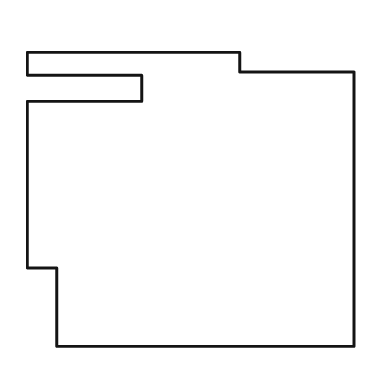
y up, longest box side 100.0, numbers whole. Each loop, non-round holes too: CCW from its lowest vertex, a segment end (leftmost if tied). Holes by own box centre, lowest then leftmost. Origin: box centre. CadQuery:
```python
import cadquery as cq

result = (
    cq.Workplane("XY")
    .moveTo(-41.0, -45.0)
    .lineTo(50.0, -45.0)
    .lineTo(50.0, 39.0)
    .lineTo(15.0, 39.0)
    .lineTo(15.0, 45.0)
    .lineTo(-50.0, 45.0)
    .lineTo(-50.0, 38.0)
    .lineTo(-15.0, 38.0)
    .lineTo(-15.0, 30.0)
    .lineTo(-50.0, 30.0)
    .lineTo(-50.0, -21.0)
    .lineTo(-41.0, -21.0)
    .close()
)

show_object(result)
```